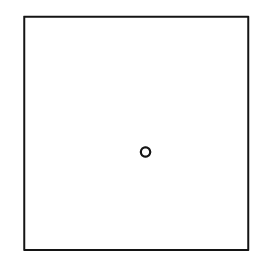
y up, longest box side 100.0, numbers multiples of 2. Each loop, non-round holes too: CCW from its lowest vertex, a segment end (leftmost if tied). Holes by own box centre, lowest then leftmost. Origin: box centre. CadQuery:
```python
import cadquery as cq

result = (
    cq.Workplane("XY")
    .moveTo(-48.0, -50.0)
    .lineTo(48.0, -50.0)
    .lineTo(48.0, 50.0)
    .lineTo(-48.0, 50.0)
    .close()
    .moveTo(4.0, -8.0)
    .circle(2.0)
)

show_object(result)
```